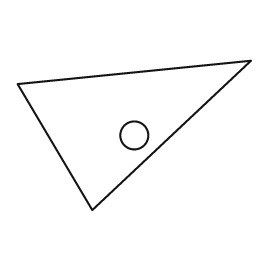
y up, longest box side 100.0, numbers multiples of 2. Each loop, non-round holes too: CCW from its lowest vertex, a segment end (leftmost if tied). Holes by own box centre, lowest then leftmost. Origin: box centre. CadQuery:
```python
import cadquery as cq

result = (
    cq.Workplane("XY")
    .moveTo(-18.0, -32.0)
    .lineTo(50.0, 32.0)
    .lineTo(-50.0, 22.0)
    .close()
    .moveTo(0.0, 0.0)
    .circle(6.0)
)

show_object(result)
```